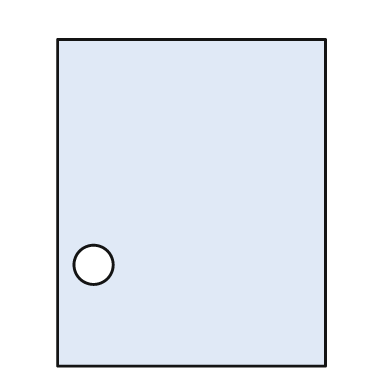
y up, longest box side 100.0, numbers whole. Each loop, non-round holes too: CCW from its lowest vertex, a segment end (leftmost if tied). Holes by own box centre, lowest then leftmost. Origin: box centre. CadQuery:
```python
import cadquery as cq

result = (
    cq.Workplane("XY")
    .moveTo(-41.0, -50.0)
    .lineTo(41.0, -50.0)
    .lineTo(41.0, 50.0)
    .lineTo(-41.0, 50.0)
    .close()
    .moveTo(-30.0, -19.0)
    .circle(6.0)
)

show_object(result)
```